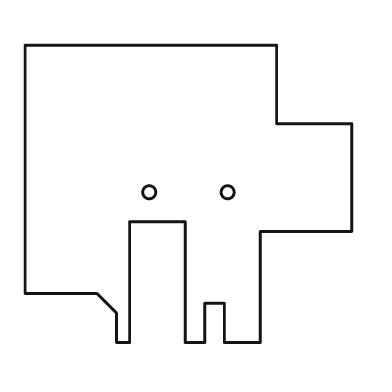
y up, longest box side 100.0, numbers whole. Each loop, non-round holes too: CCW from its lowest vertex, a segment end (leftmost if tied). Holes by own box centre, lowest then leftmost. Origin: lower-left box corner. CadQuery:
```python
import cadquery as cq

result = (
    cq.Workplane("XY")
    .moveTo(28.0, 0.0)
    .lineTo(32.0, 0.0)
    .lineTo(32.0, 37.0)
    .lineTo(49.0, 37.0)
    .lineTo(49.0, 0.0)
    .lineTo(55.0, 0.0)
    .lineTo(55.0, 12.0)
    .lineTo(61.0, 12.0)
    .lineTo(61.0, 0.0)
    .lineTo(72.0, 0.0)
    .lineTo(72.0, 34.0)
    .lineTo(100.0, 34.0)
    .lineTo(100.0, 67.0)
    .lineTo(77.0, 67.0)
    .lineTo(77.0, 91.0)
    .lineTo(0.0, 91.0)
    .lineTo(0.0, 15.0)
    .lineTo(22.0, 15.0)
    .lineTo(28.0, 9.0)
    .close()
    .moveTo(38.0, 46.0)
    .circle(2.0)
    .moveTo(62.0, 46.0)
    .circle(2.0)
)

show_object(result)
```